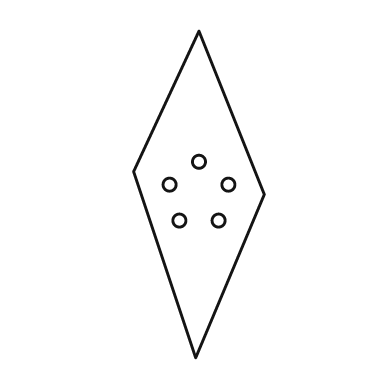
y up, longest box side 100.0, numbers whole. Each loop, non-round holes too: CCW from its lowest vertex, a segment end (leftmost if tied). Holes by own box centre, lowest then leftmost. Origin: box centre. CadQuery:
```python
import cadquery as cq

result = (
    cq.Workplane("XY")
    .moveTo(-1.0, -50.0)
    .lineTo(20.0, 0.0)
    .lineTo(0.0, 50.0)
    .lineTo(-20.0, 7.0)
    .close()
    .moveTo(-6.0, -8.0)
    .circle(2.0)
    .moveTo(6.0, -8.0)
    .circle(2.0)
    .moveTo(-9.0, 3.0)
    .circle(2.0)
    .moveTo(9.0, 3.0)
    .circle(2.0)
    .moveTo(0.0, 10.0)
    .circle(2.0)
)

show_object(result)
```